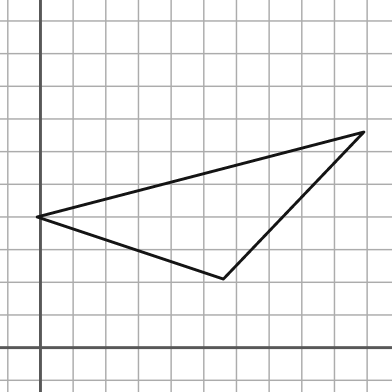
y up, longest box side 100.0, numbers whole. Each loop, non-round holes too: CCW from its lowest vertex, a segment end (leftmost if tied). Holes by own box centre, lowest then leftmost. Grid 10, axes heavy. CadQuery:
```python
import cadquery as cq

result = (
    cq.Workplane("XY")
    .moveTo(56.0, 21.0)
    .lineTo(99.0, 66.0)
    .lineTo(-1.0, 40.0)
    .close()
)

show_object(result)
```